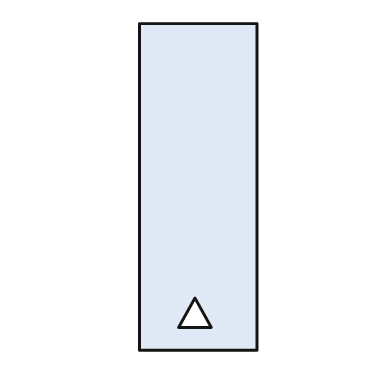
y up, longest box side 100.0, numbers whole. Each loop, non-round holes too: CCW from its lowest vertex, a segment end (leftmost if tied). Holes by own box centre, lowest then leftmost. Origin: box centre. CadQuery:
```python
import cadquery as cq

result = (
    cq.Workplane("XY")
    .moveTo(-18.0, -50.0)
    .lineTo(18.0, -50.0)
    .lineTo(18.0, 50.0)
    .lineTo(-18.0, 50.0)
    .close()
    .moveTo(-6.0, -43.0)
    .lineTo(4.0, -43.0)
    .lineTo(-1.0, -34.0)
    .close()
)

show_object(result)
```